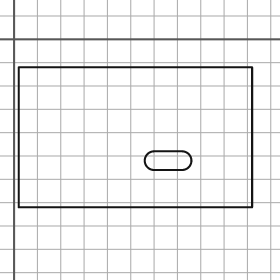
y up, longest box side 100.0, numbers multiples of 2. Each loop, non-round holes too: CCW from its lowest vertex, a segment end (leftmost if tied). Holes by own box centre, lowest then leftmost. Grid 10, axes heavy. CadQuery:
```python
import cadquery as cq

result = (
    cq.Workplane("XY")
    .moveTo(2.0, -72.0)
    .lineTo(102.0, -72.0)
    .lineTo(102.0, -12.0)
    .lineTo(2.0, -12.0)
    .close()
    .moveTo(60.0, -56.0)
    .lineTo(72.0, -56.0)
    .threePointArc((76.0, -52.0), (72.0, -48.0))
    .lineTo(60.0, -48.0)
    .threePointArc((56.0, -52.0), (60.0, -56.0))
    .close()
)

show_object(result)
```